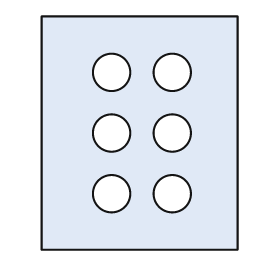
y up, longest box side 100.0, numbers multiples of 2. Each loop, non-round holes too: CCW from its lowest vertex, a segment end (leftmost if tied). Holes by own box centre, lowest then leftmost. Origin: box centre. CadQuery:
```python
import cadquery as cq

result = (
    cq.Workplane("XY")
    .moveTo(-42.0, -50.0)
    .lineTo(42.0, -50.0)
    .lineTo(42.0, 50.0)
    .lineTo(-42.0, 50.0)
    .close()
    .moveTo(-12.0, -26.0)
    .circle(8.0)
    .moveTo(14.0, -26.0)
    .circle(8.0)
    .moveTo(-12.0, 0.0)
    .circle(8.0)
    .moveTo(14.0, 0.0)
    .circle(8.0)
    .moveTo(-12.0, 26.0)
    .circle(8.0)
    .moveTo(14.0, 26.0)
    .circle(8.0)
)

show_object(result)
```